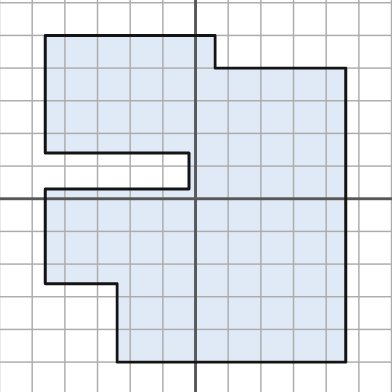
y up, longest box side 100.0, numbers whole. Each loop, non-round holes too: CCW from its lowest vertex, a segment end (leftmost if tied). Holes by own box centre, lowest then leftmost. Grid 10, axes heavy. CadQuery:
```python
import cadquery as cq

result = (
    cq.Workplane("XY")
    .moveTo(-24.0, -50.0)
    .lineTo(46.0, -50.0)
    .lineTo(46.0, 40.0)
    .lineTo(6.0, 40.0)
    .lineTo(6.0, 50.0)
    .lineTo(-46.0, 50.0)
    .lineTo(-46.0, 14.0)
    .lineTo(-2.0, 14.0)
    .lineTo(-2.0, 3.0)
    .lineTo(-46.0, 3.0)
    .lineTo(-46.0, -26.0)
    .lineTo(-24.0, -26.0)
    .close()
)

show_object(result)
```